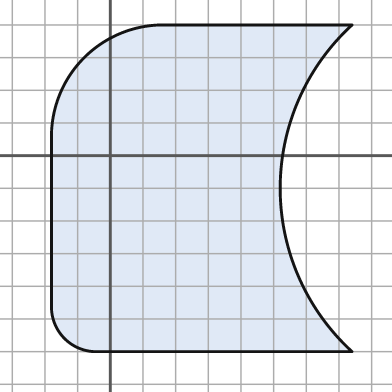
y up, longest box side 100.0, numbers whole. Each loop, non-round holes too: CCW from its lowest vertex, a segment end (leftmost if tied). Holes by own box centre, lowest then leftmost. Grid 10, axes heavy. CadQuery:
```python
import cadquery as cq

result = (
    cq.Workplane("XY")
    .moveTo(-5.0, -60.0)
    .lineTo(74.0, -60.0)
    .threePointArc((52.0, -10.0), (74.0, 40.0))
    .lineTo(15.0, 40.0)
    .threePointArc((-8.0, 30.0), (-18.0, 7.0))
    .lineTo(-18.0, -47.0)
    .threePointArc((-14.0, -56.0), (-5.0, -60.0))
    .close()
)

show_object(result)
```